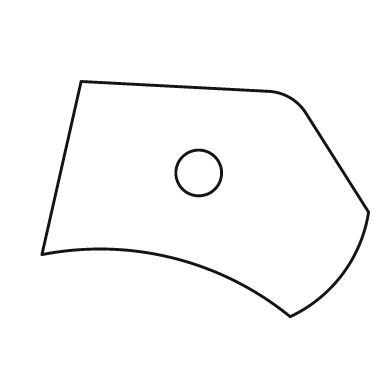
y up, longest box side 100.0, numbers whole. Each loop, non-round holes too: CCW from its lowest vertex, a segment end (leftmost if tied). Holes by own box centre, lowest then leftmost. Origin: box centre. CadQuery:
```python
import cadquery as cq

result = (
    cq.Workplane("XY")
    .moveTo(26.0, -36.0)
    .threePointArc((42.0, -23.0), (50.0, -4.0))
    .lineTo(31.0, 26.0)
    .threePointArc((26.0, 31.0), (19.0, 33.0))
    .lineTo(-38.0, 36.0)
    .lineTo(-50.0, -17.0)
    .threePointArc((-10.0, -18.0), (26.0, -36.0))
    .close()
    .moveTo(-2.0, 8.0)
    .circle(7.0)
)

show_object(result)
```